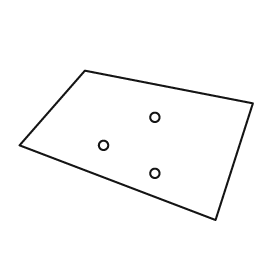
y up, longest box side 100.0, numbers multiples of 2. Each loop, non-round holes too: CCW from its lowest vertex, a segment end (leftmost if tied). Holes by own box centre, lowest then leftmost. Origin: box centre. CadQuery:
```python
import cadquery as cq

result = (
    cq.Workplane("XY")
    .moveTo(34.0, -32.0)
    .lineTo(50.0, 18.0)
    .lineTo(-22.0, 32.0)
    .lineTo(-50.0, 0.0)
    .close()
    .moveTo(8.0, -12.0)
    .circle(2.0)
    .moveTo(-14.0, 0.0)
    .circle(2.0)
    .moveTo(8.0, 12.0)
    .circle(2.0)
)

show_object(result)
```